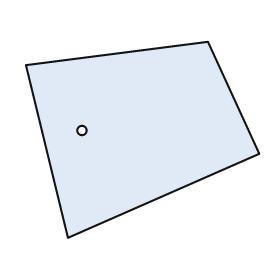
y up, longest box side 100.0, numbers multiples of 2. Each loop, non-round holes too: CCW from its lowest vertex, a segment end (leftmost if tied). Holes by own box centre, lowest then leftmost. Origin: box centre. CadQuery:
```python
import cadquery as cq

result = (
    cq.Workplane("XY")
    .moveTo(-32.0, -42.0)
    .lineTo(50.0, -6.0)
    .lineTo(28.0, 42.0)
    .lineTo(-50.0, 32.0)
    .close()
    .moveTo(-26.0, 4.0)
    .circle(2.0)
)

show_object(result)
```